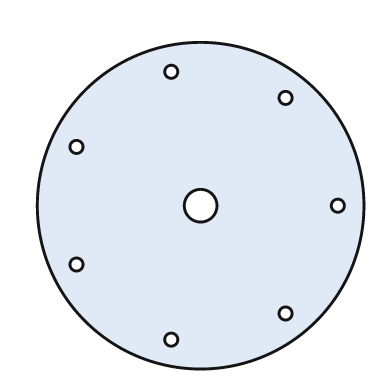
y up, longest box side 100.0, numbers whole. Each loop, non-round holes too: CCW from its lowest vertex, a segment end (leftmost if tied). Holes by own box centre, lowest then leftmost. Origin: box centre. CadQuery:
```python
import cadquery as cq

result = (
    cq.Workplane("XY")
    .moveTo(0.0, 0.0)
    .circle(50.0)
    .moveTo(-9.0, -41.0)
    .circle(2.0)
    .moveTo(26.0, -33.0)
    .circle(2.0)
    .moveTo(-38.0, -18.0)
    .circle(2.0)
    .moveTo(0.0, 0.0)
    .circle(5.0)
    .moveTo(42.0, 0.0)
    .circle(2.0)
    .moveTo(-38.0, 18.0)
    .circle(2.0)
    .moveTo(26.0, 33.0)
    .circle(2.0)
    .moveTo(-9.0, 41.0)
    .circle(2.0)
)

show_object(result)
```